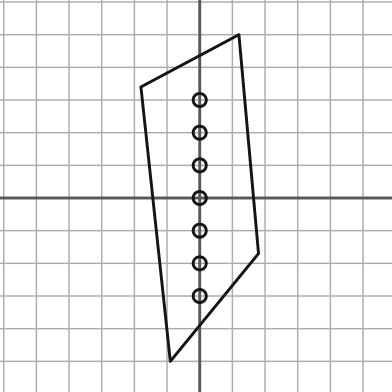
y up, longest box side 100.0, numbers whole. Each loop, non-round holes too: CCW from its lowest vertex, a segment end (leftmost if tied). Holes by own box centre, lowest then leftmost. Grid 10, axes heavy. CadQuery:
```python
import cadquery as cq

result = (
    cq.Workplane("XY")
    .moveTo(-9.0, -50.0)
    .lineTo(18.0, -17.0)
    .lineTo(12.0, 50.0)
    .lineTo(-18.0, 34.0)
    .close()
    .moveTo(0.0, -30.0)
    .circle(2.0)
    .moveTo(0.0, -20.0)
    .circle(2.0)
    .moveTo(0.0, -10.0)
    .circle(2.0)
    .moveTo(0.0, 0.0)
    .circle(2.0)
    .moveTo(0.0, 10.0)
    .circle(2.0)
    .moveTo(0.0, 20.0)
    .circle(2.0)
    .moveTo(0.0, 30.0)
    .circle(2.0)
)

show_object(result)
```